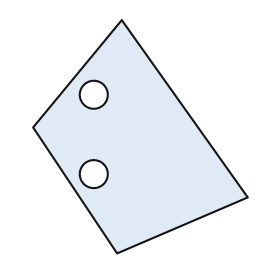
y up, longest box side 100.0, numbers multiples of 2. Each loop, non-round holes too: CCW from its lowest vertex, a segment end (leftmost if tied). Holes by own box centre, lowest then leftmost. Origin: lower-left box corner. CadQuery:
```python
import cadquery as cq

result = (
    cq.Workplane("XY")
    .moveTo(36.0, 0.0)
    .lineTo(92.0, 24.0)
    .lineTo(38.0, 100.0)
    .lineTo(0.0, 54.0)
    .close()
    .moveTo(26.0, 34.0)
    .circle(6.0)
    .moveTo(26.0, 68.0)
    .circle(6.0)
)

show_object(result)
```